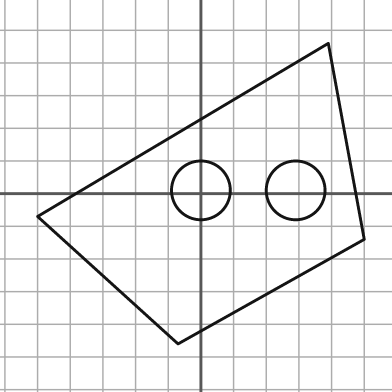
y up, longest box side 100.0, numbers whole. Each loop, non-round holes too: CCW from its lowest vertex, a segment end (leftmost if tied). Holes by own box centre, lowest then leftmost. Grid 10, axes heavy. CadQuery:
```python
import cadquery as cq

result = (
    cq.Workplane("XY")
    .moveTo(-7.0, -46.0)
    .lineTo(50.0, -14.0)
    .lineTo(39.0, 46.0)
    .lineTo(-50.0, -7.0)
    .close()
    .moveTo(0.0, 1.0)
    .circle(9.0)
    .moveTo(29.0, 1.0)
    .circle(9.0)
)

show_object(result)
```